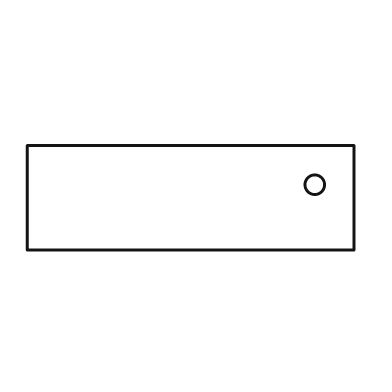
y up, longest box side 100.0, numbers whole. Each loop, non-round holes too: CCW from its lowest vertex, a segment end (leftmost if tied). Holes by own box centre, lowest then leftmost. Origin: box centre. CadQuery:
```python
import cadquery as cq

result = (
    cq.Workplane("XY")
    .moveTo(-50.0, -16.0)
    .lineTo(50.0, -16.0)
    .lineTo(50.0, 16.0)
    .lineTo(-50.0, 16.0)
    .close()
    .moveTo(38.0, 4.0)
    .circle(3.0)
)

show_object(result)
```